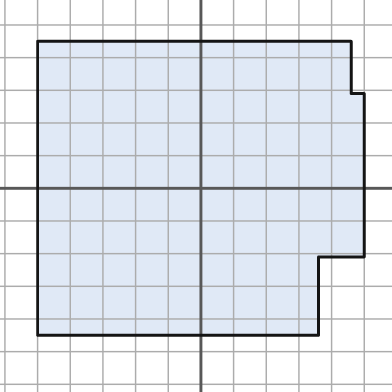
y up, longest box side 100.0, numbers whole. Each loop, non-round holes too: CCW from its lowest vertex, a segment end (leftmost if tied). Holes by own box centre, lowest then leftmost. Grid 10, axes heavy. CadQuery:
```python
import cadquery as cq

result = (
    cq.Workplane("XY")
    .moveTo(-50.0, -45.0)
    .lineTo(36.0, -45.0)
    .lineTo(36.0, -21.0)
    .lineTo(50.0, -21.0)
    .lineTo(50.0, 29.0)
    .lineTo(46.0, 29.0)
    .lineTo(46.0, 45.0)
    .lineTo(-50.0, 45.0)
    .close()
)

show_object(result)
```